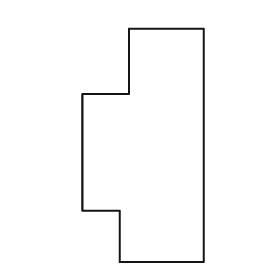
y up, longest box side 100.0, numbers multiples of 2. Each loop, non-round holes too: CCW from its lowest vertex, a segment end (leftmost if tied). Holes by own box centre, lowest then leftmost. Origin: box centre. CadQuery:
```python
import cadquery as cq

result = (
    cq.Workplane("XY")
    .moveTo(-10.0, -50.0)
    .lineTo(26.0, -50.0)
    .lineTo(26.0, 50.0)
    .lineTo(-6.0, 50.0)
    .lineTo(-6.0, 22.0)
    .lineTo(-26.0, 22.0)
    .lineTo(-26.0, -28.0)
    .lineTo(-10.0, -28.0)
    .close()
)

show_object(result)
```